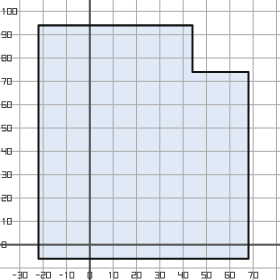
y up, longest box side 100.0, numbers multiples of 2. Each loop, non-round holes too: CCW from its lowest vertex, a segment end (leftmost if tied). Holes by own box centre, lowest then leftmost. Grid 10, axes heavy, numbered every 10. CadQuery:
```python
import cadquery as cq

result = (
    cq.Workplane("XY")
    .moveTo(-22.0, -6.0)
    .lineTo(68.0, -6.0)
    .lineTo(68.0, 74.0)
    .lineTo(44.0, 74.0)
    .lineTo(44.0, 94.0)
    .lineTo(-22.0, 94.0)
    .close()
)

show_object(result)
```